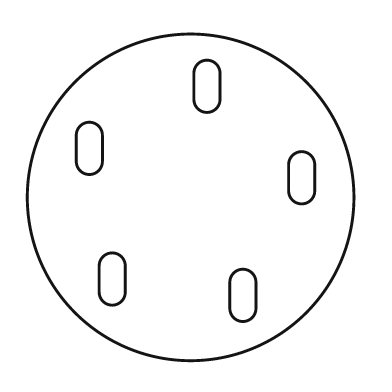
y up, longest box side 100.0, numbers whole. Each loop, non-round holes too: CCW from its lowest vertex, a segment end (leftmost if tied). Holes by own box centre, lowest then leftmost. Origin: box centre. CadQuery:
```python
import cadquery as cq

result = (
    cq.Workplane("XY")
    .moveTo(0.0, 0.0)
    .circle(50.0)
    .moveTo(12.0, -34.0)
    .threePointArc((16.0, -38.0), (20.0, -34.0))
    .lineTo(20.0, -26.0)
    .threePointArc((16.0, -22.0), (12.0, -26.0))
    .close()
    .moveTo(-28.0, -29.0)
    .threePointArc((-24.0, -33.0), (-20.0, -29.0))
    .lineTo(-20.0, -21.0)
    .threePointArc((-24.0, -17.0), (-28.0, -21.0))
    .close()
    .moveTo(30.0, 2.0)
    .threePointArc((34.0, -2.0), (38.0, 2.0))
    .lineTo(38.0, 10.0)
    .threePointArc((34.0, 14.0), (30.0, 10.0))
    .close()
    .moveTo(-35.0, 11.0)
    .threePointArc((-31.0, 7.0), (-27.0, 11.0))
    .lineTo(-27.0, 19.0)
    .threePointArc((-31.0, 23.0), (-35.0, 19.0))
    .close()
    .moveTo(1.0, 30.0)
    .threePointArc((5.0, 26.0), (9.0, 30.0))
    .lineTo(9.0, 38.0)
    .threePointArc((5.0, 42.0), (1.0, 38.0))
    .close()
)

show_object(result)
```